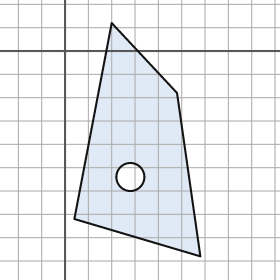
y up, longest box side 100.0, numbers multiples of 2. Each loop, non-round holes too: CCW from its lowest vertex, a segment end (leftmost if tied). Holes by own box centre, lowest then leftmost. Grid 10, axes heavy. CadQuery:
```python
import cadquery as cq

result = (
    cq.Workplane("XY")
    .moveTo(58.0, -88.0)
    .lineTo(48.0, -18.0)
    .lineTo(20.0, 12.0)
    .lineTo(4.0, -72.0)
    .close()
    .moveTo(28.0, -54.0)
    .circle(6.0)
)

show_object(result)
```